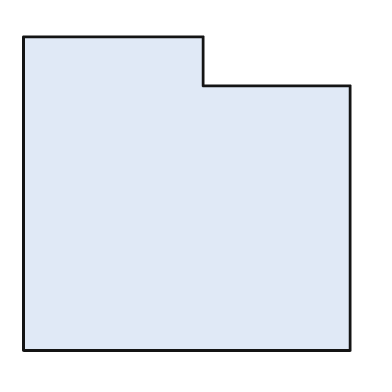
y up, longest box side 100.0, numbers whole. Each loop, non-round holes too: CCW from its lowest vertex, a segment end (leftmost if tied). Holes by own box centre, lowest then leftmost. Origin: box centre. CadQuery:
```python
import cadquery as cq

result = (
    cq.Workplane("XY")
    .moveTo(-50.0, -48.0)
    .lineTo(50.0, -48.0)
    .lineTo(50.0, 33.0)
    .lineTo(5.0, 33.0)
    .lineTo(5.0, 48.0)
    .lineTo(-50.0, 48.0)
    .close()
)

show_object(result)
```